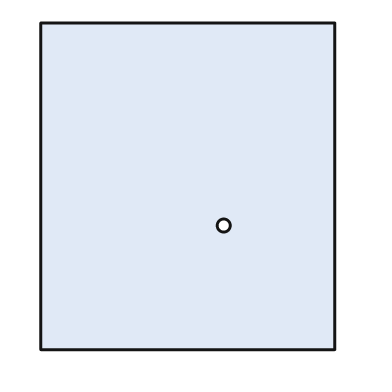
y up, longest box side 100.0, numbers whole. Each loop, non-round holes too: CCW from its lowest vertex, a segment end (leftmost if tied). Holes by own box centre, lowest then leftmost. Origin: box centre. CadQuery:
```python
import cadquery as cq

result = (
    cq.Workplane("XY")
    .moveTo(-45.0, -50.0)
    .lineTo(45.0, -50.0)
    .lineTo(45.0, 50.0)
    .lineTo(-45.0, 50.0)
    .close()
    .moveTo(11.0, -12.0)
    .circle(2.0)
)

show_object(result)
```